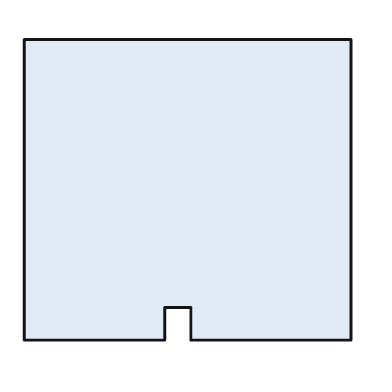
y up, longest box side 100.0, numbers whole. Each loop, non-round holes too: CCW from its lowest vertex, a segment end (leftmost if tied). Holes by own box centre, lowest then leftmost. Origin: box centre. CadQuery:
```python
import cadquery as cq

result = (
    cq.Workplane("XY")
    .moveTo(-50.0, -46.0)
    .lineTo(-7.0, -46.0)
    .lineTo(-7.0, -36.0)
    .lineTo(1.0, -36.0)
    .lineTo(1.0, -46.0)
    .lineTo(50.0, -46.0)
    .lineTo(50.0, 46.0)
    .lineTo(-50.0, 46.0)
    .close()
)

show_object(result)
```